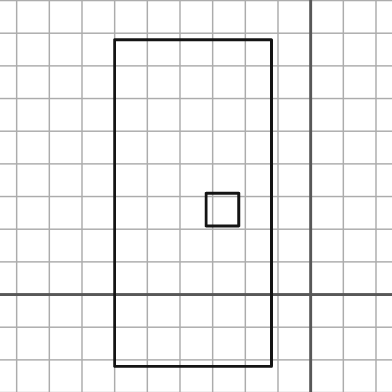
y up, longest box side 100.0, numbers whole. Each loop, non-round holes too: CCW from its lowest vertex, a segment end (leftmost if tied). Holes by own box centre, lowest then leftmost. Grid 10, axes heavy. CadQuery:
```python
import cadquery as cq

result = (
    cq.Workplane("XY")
    .moveTo(-60.0, -22.0)
    .lineTo(-12.0, -22.0)
    .lineTo(-12.0, 78.0)
    .lineTo(-60.0, 78.0)
    .close()
    .moveTo(-32.0, 21.0)
    .lineTo(-22.0, 21.0)
    .lineTo(-22.0, 31.0)
    .lineTo(-32.0, 31.0)
    .close()
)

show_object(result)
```